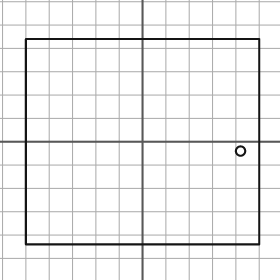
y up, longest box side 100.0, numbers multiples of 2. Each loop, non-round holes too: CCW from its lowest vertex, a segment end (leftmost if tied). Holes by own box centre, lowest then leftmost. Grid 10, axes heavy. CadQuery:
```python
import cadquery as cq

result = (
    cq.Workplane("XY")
    .moveTo(-50.0, -44.0)
    .lineTo(50.0, -44.0)
    .lineTo(50.0, 44.0)
    .lineTo(-50.0, 44.0)
    .close()
    .moveTo(42.0, -4.0)
    .circle(2.0)
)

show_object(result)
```